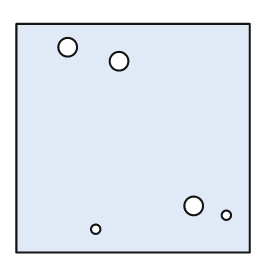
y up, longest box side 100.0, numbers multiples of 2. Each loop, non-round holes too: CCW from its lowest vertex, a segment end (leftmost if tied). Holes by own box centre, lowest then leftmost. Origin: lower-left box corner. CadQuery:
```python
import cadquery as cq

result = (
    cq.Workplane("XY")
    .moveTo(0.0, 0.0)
    .lineTo(100.0, 0.0)
    .lineTo(100.0, 98.0)
    .lineTo(0.0, 98.0)
    .close()
    .moveTo(34.0, 10.0)
    .circle(2.0)
    .moveTo(90.0, 16.0)
    .circle(2.0)
    .moveTo(76.0, 20.0)
    .circle(4.0)
    .moveTo(44.0, 82.0)
    .circle(4.0)
    .moveTo(22.0, 88.0)
    .circle(4.0)
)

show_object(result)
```